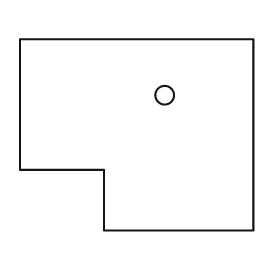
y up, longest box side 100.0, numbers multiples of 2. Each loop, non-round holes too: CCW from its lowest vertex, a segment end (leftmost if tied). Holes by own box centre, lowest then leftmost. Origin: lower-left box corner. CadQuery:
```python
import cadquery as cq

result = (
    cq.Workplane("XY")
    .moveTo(36.0, 0.0)
    .lineTo(100.0, 0.0)
    .lineTo(100.0, 82.0)
    .lineTo(0.0, 82.0)
    .lineTo(0.0, 26.0)
    .lineTo(36.0, 26.0)
    .close()
    .moveTo(62.0, 58.0)
    .circle(4.0)
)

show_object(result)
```